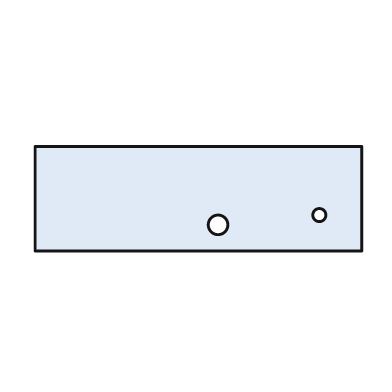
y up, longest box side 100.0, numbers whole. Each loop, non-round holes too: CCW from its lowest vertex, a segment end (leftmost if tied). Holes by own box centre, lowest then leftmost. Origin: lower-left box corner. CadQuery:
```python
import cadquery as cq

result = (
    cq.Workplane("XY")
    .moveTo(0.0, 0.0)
    .lineTo(100.0, 0.0)
    .lineTo(100.0, 32.0)
    .lineTo(0.0, 32.0)
    .close()
    .moveTo(56.0, 8.0)
    .circle(3.0)
    .moveTo(87.0, 11.0)
    .circle(2.0)
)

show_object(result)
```